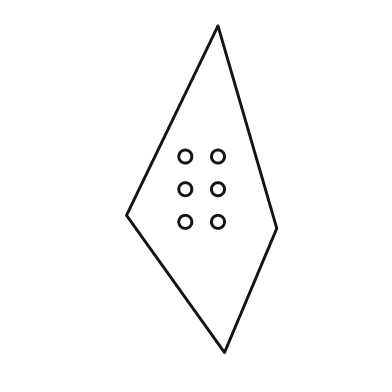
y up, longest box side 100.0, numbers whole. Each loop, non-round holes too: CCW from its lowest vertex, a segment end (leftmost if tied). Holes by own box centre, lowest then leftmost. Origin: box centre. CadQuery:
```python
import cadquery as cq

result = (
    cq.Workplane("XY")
    .moveTo(7.0, -50.0)
    .lineTo(23.0, -12.0)
    .lineTo(5.0, 50.0)
    .lineTo(-23.0, -8.0)
    .close()
    .moveTo(-5.0, -10.0)
    .circle(2.0)
    .moveTo(5.0, -10.0)
    .circle(2.0)
    .moveTo(-5.0, 0.0)
    .circle(2.0)
    .moveTo(5.0, 0.0)
    .circle(2.0)
    .moveTo(-5.0, 10.0)
    .circle(2.0)
    .moveTo(5.0, 10.0)
    .circle(2.0)
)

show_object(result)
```